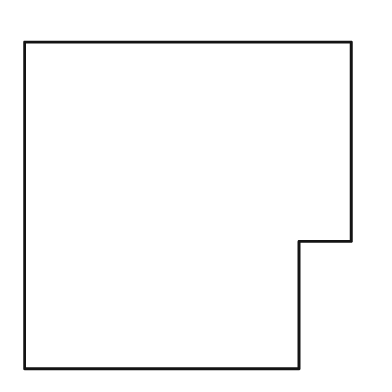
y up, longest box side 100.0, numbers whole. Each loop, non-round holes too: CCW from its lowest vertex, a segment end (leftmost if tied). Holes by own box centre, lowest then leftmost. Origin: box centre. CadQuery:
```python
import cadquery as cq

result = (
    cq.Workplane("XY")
    .moveTo(-50.0, -50.0)
    .lineTo(34.0, -50.0)
    .lineTo(34.0, -11.0)
    .lineTo(50.0, -11.0)
    .lineTo(50.0, 50.0)
    .lineTo(-50.0, 50.0)
    .close()
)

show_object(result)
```